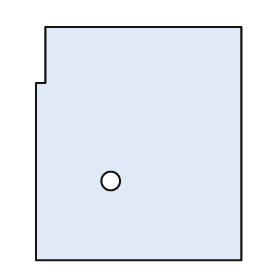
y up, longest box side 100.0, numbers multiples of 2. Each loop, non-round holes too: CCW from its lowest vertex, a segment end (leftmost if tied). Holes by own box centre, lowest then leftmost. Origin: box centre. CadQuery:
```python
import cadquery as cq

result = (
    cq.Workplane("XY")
    .moveTo(-44.0, -50.0)
    .lineTo(44.0, -50.0)
    .lineTo(44.0, 50.0)
    .lineTo(-40.0, 50.0)
    .lineTo(-40.0, 26.0)
    .lineTo(-44.0, 26.0)
    .close()
    .moveTo(-12.0, -16.0)
    .circle(4.0)
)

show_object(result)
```